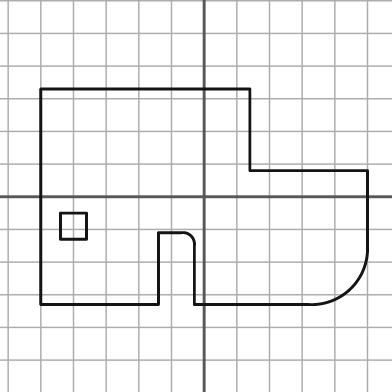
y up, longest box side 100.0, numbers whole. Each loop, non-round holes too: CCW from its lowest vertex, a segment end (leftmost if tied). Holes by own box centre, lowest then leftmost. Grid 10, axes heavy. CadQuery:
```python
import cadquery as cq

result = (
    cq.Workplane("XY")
    .moveTo(-50.0, -33.0)
    .lineTo(-14.0, -33.0)
    .lineTo(-14.0, -11.0)
    .lineTo(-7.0, -11.0)
    .threePointArc((-4.0, -12.0), (-3.0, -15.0))
    .lineTo(-3.0, -33.0)
    .lineTo(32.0, -33.0)
    .threePointArc((45.0, -28.0), (50.0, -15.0))
    .lineTo(50.0, 8.0)
    .lineTo(14.0, 8.0)
    .lineTo(14.0, 33.0)
    .lineTo(-50.0, 33.0)
    .close()
    .moveTo(-44.0, -13.0)
    .lineTo(-36.0, -13.0)
    .lineTo(-36.0, -5.0)
    .lineTo(-44.0, -5.0)
    .close()
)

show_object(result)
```